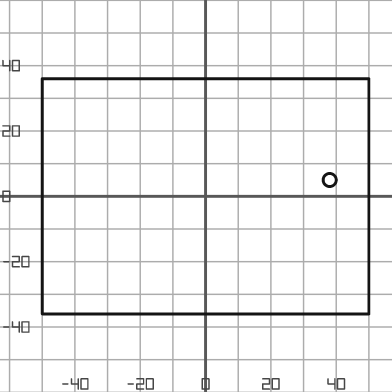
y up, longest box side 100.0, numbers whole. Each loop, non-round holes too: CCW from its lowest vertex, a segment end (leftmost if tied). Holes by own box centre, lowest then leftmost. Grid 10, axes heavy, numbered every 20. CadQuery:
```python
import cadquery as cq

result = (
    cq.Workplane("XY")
    .moveTo(-50.0, -36.0)
    .lineTo(50.0, -36.0)
    .lineTo(50.0, 36.0)
    .lineTo(-50.0, 36.0)
    .close()
    .moveTo(38.0, 5.0)
    .circle(2.0)
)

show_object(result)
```